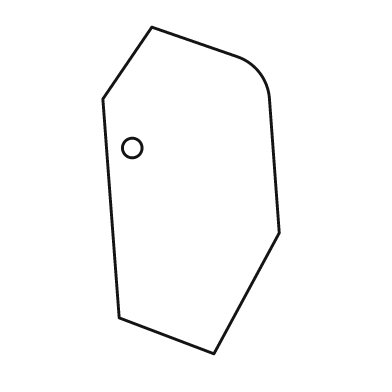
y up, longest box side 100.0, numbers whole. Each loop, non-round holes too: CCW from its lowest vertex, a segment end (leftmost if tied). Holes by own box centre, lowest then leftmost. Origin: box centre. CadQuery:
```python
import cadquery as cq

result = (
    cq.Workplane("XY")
    .moveTo(7.0, -50.0)
    .lineTo(27.0, -13.0)
    .lineTo(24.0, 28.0)
    .threePointArc((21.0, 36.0), (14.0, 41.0))
    .lineTo(-12.0, 50.0)
    .lineTo(-27.0, 28.0)
    .lineTo(-22.0, -39.0)
    .close()
    .moveTo(-18.0, 13.0)
    .circle(3.0)
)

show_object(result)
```